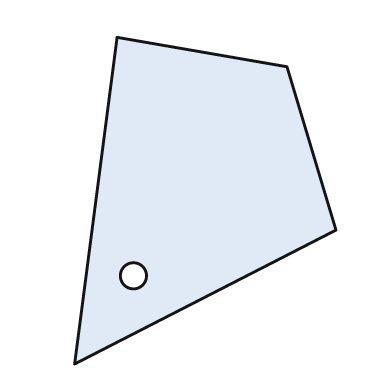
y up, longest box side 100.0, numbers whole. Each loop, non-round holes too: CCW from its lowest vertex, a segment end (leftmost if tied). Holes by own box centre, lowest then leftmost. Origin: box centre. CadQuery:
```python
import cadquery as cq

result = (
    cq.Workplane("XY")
    .moveTo(-40.0, -50.0)
    .lineTo(40.0, -9.0)
    .lineTo(25.0, 41.0)
    .lineTo(-27.0, 50.0)
    .close()
    .moveTo(-22.0, -23.0)
    .circle(4.0)
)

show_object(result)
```